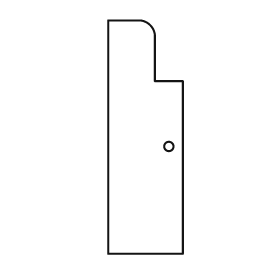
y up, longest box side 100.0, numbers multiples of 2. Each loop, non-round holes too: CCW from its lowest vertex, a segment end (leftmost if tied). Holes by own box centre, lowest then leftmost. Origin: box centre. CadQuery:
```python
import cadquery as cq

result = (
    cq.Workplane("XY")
    .moveTo(-16.0, -50.0)
    .lineTo(16.0, -50.0)
    .lineTo(16.0, 24.0)
    .lineTo(4.0, 24.0)
    .lineTo(4.0, 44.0)
    .threePointArc((2.0, 48.0), (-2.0, 50.0))
    .lineTo(-16.0, 50.0)
    .close()
    .moveTo(10.0, -4.0)
    .circle(2.0)
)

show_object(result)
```